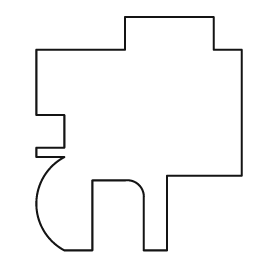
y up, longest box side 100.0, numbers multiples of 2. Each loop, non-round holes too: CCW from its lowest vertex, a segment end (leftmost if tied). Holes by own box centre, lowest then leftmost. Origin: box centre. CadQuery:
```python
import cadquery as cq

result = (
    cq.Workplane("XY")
    .moveTo(-32.0, -50.0)
    .lineTo(-20.0, -50.0)
    .lineTo(-20.0, -20.0)
    .lineTo(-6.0, -20.0)
    .threePointArc((0.0, -22.0), (2.0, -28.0))
    .lineTo(2.0, -50.0)
    .lineTo(12.0, -50.0)
    .lineTo(12.0, -18.0)
    .lineTo(44.0, -18.0)
    .lineTo(44.0, 36.0)
    .lineTo(32.0, 36.0)
    .lineTo(32.0, 50.0)
    .lineTo(-6.0, 50.0)
    .lineTo(-6.0, 36.0)
    .lineTo(-44.0, 36.0)
    .lineTo(-44.0, 8.0)
    .lineTo(-32.0, 8.0)
    .lineTo(-32.0, -6.0)
    .lineTo(-44.0, -6.0)
    .lineTo(-44.0, -10.0)
    .lineTo(-32.0, -10.0)
    .threePointArc((-44.0, -30.0), (-32.0, -50.0))
    .close()
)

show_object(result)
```